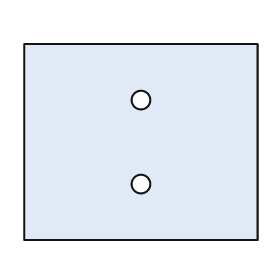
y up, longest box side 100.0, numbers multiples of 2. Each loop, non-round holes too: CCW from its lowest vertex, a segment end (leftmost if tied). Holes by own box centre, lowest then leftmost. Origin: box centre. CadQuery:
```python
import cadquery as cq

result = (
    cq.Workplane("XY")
    .moveTo(-50.0, -42.0)
    .lineTo(50.0, -42.0)
    .lineTo(50.0, 42.0)
    .lineTo(-50.0, 42.0)
    .close()
    .moveTo(0.0, -18.0)
    .circle(4.0)
    .moveTo(0.0, 18.0)
    .circle(4.0)
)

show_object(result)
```